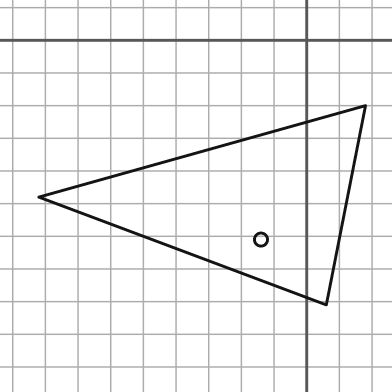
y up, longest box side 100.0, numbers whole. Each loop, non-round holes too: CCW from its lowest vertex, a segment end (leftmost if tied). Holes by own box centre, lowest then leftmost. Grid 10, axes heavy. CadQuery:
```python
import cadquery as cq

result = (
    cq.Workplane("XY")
    .moveTo(6.0, -81.0)
    .lineTo(18.0, -20.0)
    .lineTo(-82.0, -48.0)
    .close()
    .moveTo(-14.0, -61.0)
    .circle(2.0)
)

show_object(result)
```